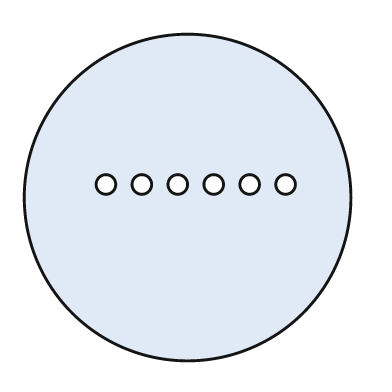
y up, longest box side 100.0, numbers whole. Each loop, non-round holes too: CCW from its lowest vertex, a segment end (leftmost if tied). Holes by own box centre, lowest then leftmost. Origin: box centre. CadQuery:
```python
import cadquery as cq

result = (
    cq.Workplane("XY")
    .moveTo(0.0, 0.0)
    .circle(50.0)
    .moveTo(-25.0, 4.0)
    .circle(3.0)
    .moveTo(-14.0, 4.0)
    .circle(3.0)
    .moveTo(-3.0, 4.0)
    .circle(3.0)
    .moveTo(8.0, 4.0)
    .circle(3.0)
    .moveTo(19.0, 4.0)
    .circle(3.0)
    .moveTo(30.0, 4.0)
    .circle(3.0)
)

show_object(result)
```